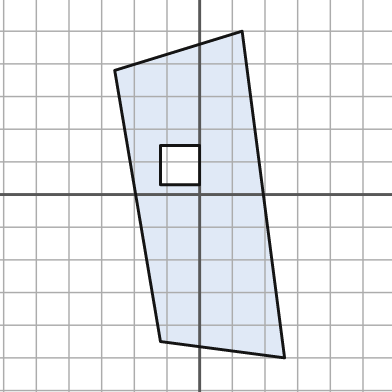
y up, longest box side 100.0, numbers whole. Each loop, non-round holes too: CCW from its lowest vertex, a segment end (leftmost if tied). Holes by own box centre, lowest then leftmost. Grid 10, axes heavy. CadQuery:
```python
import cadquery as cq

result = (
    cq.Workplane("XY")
    .moveTo(26.0, -50.0)
    .lineTo(13.0, 50.0)
    .lineTo(-26.0, 38.0)
    .lineTo(-12.0, -45.0)
    .close()
    .moveTo(-12.0, 3.0)
    .lineTo(0.0, 3.0)
    .lineTo(0.0, 15.0)
    .lineTo(-12.0, 15.0)
    .close()
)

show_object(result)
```